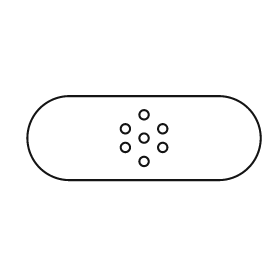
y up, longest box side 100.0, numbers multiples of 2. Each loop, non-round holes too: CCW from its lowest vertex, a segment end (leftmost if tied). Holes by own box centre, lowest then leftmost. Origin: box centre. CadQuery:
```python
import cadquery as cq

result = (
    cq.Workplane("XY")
    .moveTo(-32.0, -18.0)
    .lineTo(32.0, -18.0)
    .threePointArc((50.0, 0.0), (32.0, 18.0))
    .lineTo(-32.0, 18.0)
    .threePointArc((-50.0, 0.0), (-32.0, -18.0))
    .close()
    .moveTo(0.0, -10.0)
    .circle(2.0)
    .moveTo(-8.0, -4.0)
    .circle(2.0)
    .moveTo(8.0, -4.0)
    .circle(2.0)
    .moveTo(0.0, 0.0)
    .circle(2.0)
    .moveTo(-8.0, 4.0)
    .circle(2.0)
    .moveTo(8.0, 4.0)
    .circle(2.0)
    .moveTo(0.0, 10.0)
    .circle(2.0)
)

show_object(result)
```